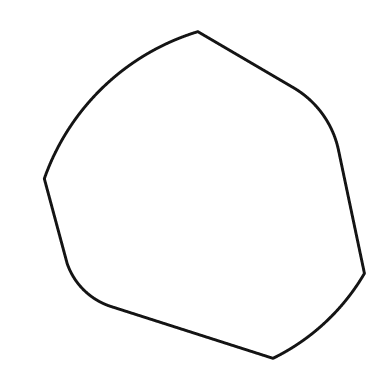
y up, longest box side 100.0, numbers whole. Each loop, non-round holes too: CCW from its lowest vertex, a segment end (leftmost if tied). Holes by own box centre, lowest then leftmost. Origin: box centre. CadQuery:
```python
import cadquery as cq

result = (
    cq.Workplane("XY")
    .moveTo(21.0, -50.0)
    .threePointArc((37.0, -39.0), (49.0, -24.0))
    .lineTo(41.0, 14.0)
    .threePointArc((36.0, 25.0), (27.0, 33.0))
    .lineTo(-2.0, 50.0)
    .threePointArc((-31.0, 33.0), (-49.0, 5.0))
    .lineTo(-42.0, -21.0)
    .threePointArc((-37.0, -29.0), (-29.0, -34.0))
    .close()
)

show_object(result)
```